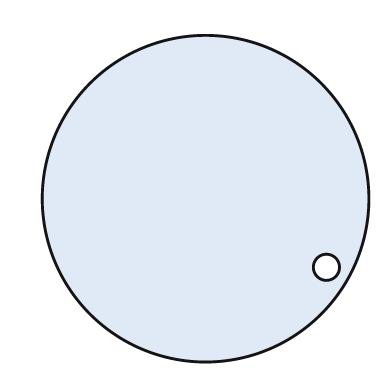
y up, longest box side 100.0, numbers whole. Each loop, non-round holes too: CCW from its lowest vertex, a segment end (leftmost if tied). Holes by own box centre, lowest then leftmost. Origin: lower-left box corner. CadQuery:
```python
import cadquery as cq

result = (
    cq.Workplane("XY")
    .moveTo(50.0, 50.0)
    .circle(50.0)
    .moveTo(87.0, 29.0)
    .circle(4.0)
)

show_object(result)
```